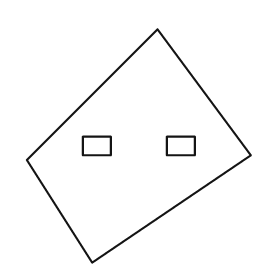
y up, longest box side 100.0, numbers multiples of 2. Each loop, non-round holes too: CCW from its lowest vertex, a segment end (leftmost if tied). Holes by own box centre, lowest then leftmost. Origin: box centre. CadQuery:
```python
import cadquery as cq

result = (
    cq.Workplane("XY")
    .moveTo(-20.0, -50.0)
    .lineTo(48.0, -4.0)
    .lineTo(8.0, 50.0)
    .lineTo(-48.0, -6.0)
    .close()
    .moveTo(-24.0, -4.0)
    .lineTo(-12.0, -4.0)
    .lineTo(-12.0, 4.0)
    .lineTo(-24.0, 4.0)
    .close()
    .moveTo(12.0, -4.0)
    .lineTo(24.0, -4.0)
    .lineTo(24.0, 4.0)
    .lineTo(12.0, 4.0)
    .close()
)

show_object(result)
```